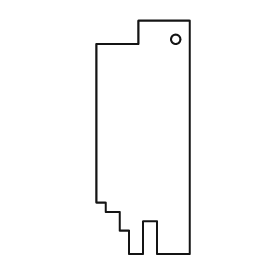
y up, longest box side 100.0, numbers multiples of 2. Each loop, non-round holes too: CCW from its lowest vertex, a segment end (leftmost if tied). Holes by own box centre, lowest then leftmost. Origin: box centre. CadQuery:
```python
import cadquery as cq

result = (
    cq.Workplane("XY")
    .moveTo(-6.0, -50.0)
    .lineTo(0.0, -50.0)
    .lineTo(0.0, -36.0)
    .lineTo(6.0, -36.0)
    .lineTo(6.0, -50.0)
    .lineTo(20.0, -50.0)
    .lineTo(20.0, 50.0)
    .lineTo(-2.0, 50.0)
    .lineTo(-2.0, 40.0)
    .lineTo(-20.0, 40.0)
    .lineTo(-20.0, -28.0)
    .lineTo(-16.0, -28.0)
    .lineTo(-16.0, -32.0)
    .lineTo(-10.0, -32.0)
    .lineTo(-10.0, -40.0)
    .lineTo(-6.0, -40.0)
    .close()
    .moveTo(14.0, 42.0)
    .circle(2.0)
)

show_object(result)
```